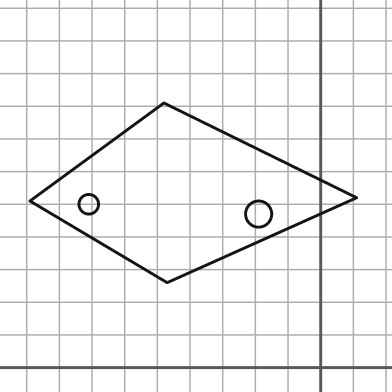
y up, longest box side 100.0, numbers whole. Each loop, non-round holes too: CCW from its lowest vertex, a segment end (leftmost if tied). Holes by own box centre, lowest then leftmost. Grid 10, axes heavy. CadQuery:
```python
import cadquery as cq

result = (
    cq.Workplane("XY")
    .moveTo(-47.0, 26.0)
    .lineTo(11.0, 52.0)
    .lineTo(-48.0, 81.0)
    .lineTo(-89.0, 51.0)
    .close()
    .moveTo(-19.0, 47.0)
    .circle(4.0)
    .moveTo(-71.0, 50.0)
    .circle(3.0)
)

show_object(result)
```